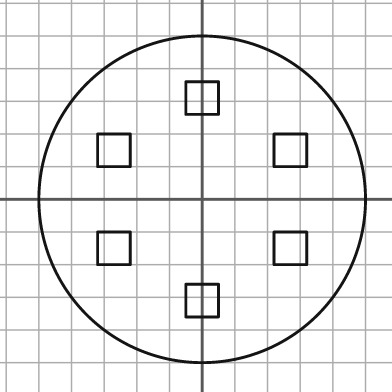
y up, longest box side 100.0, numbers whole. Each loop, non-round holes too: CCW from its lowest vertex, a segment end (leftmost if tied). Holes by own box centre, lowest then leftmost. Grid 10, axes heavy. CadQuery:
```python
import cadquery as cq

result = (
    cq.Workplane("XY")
    .moveTo(0.0, 0.0)
    .circle(50.0)
    .moveTo(-5.0, -36.0)
    .lineTo(5.0, -36.0)
    .lineTo(5.0, -26.0)
    .lineTo(-5.0, -26.0)
    .close()
    .moveTo(-32.0, -20.0)
    .lineTo(-22.0, -20.0)
    .lineTo(-22.0, -10.0)
    .lineTo(-32.0, -10.0)
    .close()
    .moveTo(22.0, -20.0)
    .lineTo(32.0, -20.0)
    .lineTo(32.0, -10.0)
    .lineTo(22.0, -10.0)
    .close()
    .moveTo(-32.0, 10.0)
    .lineTo(-22.0, 10.0)
    .lineTo(-22.0, 20.0)
    .lineTo(-32.0, 20.0)
    .close()
    .moveTo(22.0, 10.0)
    .lineTo(32.0, 10.0)
    .lineTo(32.0, 20.0)
    .lineTo(22.0, 20.0)
    .close()
    .moveTo(-5.0, 26.0)
    .lineTo(5.0, 26.0)
    .lineTo(5.0, 36.0)
    .lineTo(-5.0, 36.0)
    .close()
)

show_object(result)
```